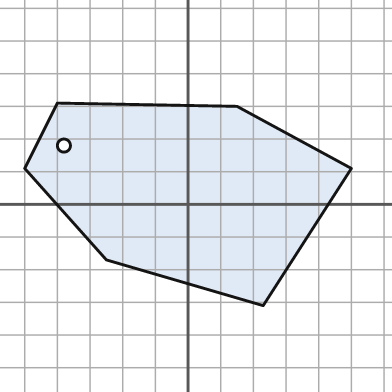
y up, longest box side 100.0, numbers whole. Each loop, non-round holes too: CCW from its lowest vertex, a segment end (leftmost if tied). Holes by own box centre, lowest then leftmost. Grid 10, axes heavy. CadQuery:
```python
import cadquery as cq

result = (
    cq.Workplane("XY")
    .moveTo(23.0, -31.0)
    .lineTo(50.0, 11.0)
    .lineTo(15.0, 30.0)
    .lineTo(-40.0, 31.0)
    .lineTo(-50.0, 11.0)
    .lineTo(-25.0, -17.0)
    .close()
    .moveTo(-38.0, 18.0)
    .circle(2.0)
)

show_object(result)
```